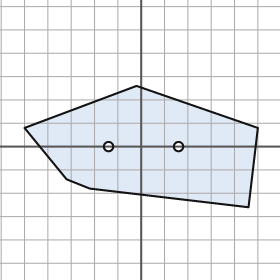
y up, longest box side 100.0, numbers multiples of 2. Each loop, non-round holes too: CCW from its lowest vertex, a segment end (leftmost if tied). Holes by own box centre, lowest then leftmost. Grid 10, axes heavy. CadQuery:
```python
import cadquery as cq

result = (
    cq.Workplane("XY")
    .moveTo(46.0, -26.0)
    .lineTo(50.0, 8.0)
    .lineTo(-2.0, 26.0)
    .lineTo(-50.0, 8.0)
    .lineTo(-32.0, -14.0)
    .lineTo(-22.0, -18.0)
    .close()
    .moveTo(-14.0, 0.0)
    .circle(2.0)
    .moveTo(16.0, 0.0)
    .circle(2.0)
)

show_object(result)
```